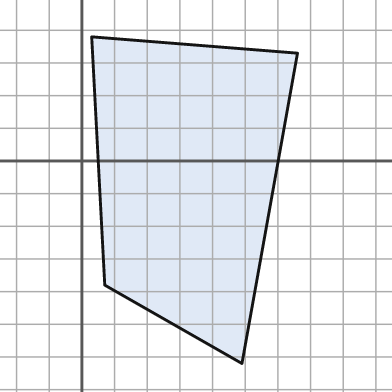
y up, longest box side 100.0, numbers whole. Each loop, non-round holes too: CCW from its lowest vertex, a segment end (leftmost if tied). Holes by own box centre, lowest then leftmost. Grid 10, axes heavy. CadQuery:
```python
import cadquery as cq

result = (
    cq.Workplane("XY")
    .moveTo(49.0, -62.0)
    .lineTo(66.0, 33.0)
    .lineTo(3.0, 38.0)
    .lineTo(7.0, -38.0)
    .close()
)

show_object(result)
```